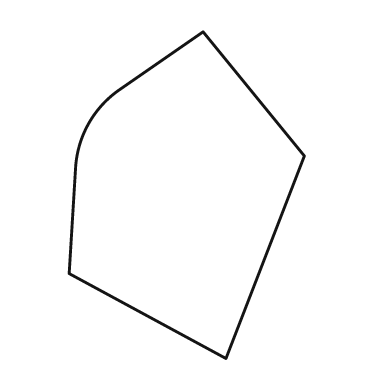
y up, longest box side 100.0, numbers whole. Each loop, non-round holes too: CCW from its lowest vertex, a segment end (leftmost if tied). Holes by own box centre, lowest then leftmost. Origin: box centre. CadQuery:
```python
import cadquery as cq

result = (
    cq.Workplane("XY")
    .moveTo(12.0, -50.0)
    .lineTo(36.0, 12.0)
    .lineTo(5.0, 50.0)
    .lineTo(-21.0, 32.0)
    .threePointArc((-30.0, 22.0), (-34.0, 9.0))
    .lineTo(-36.0, -24.0)
    .close()
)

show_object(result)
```